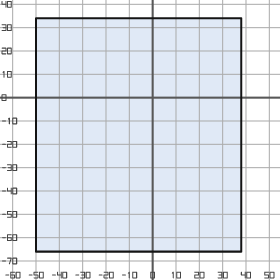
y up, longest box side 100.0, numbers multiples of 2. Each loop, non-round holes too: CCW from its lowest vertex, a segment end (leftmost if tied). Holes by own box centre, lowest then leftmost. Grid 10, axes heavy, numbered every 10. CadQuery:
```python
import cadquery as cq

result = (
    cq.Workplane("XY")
    .moveTo(-50.0, -66.0)
    .lineTo(38.0, -66.0)
    .lineTo(38.0, 34.0)
    .lineTo(-50.0, 34.0)
    .close()
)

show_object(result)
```